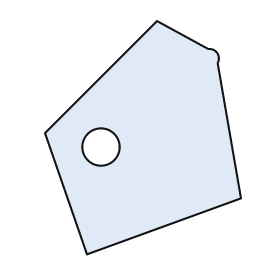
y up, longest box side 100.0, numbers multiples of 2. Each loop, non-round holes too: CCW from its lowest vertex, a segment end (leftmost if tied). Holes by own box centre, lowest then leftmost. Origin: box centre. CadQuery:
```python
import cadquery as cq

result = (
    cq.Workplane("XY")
    .moveTo(-24.0, -50.0)
    .lineTo(42.0, -26.0)
    .lineTo(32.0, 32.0)
    .threePointArc((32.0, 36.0), (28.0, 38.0))
    .lineTo(6.0, 50.0)
    .lineTo(-42.0, 2.0)
    .close()
    .moveTo(-18.0, -4.0)
    .circle(8.0)
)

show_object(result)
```